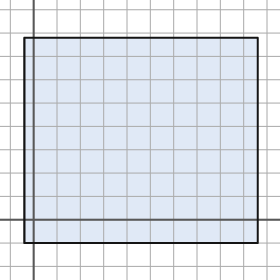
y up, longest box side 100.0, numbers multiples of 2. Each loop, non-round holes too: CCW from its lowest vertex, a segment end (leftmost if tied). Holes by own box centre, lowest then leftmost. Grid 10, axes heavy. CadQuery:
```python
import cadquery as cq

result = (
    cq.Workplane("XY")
    .moveTo(-4.0, -10.0)
    .lineTo(96.0, -10.0)
    .lineTo(96.0, 78.0)
    .lineTo(-4.0, 78.0)
    .close()
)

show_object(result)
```